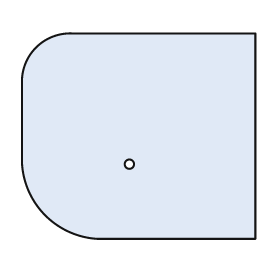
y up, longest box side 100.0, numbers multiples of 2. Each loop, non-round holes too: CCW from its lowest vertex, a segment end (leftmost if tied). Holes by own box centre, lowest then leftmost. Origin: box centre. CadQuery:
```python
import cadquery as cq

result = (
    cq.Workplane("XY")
    .moveTo(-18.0, -44.0)
    .lineTo(50.0, -44.0)
    .lineTo(50.0, 44.0)
    .lineTo(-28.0, 44.0)
    .threePointArc((-44.0, 38.0), (-50.0, 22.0))
    .lineTo(-50.0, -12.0)
    .threePointArc((-40.0, -34.0), (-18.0, -44.0))
    .close()
    .moveTo(-4.0, -12.0)
    .circle(2.0)
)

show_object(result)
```